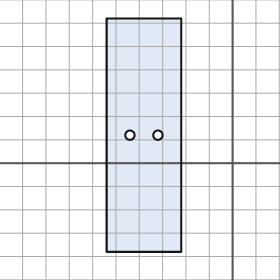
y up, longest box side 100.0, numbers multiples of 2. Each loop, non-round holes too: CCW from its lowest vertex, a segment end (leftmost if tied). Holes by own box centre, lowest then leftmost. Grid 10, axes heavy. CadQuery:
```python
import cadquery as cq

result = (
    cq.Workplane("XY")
    .moveTo(-54.0, -38.0)
    .lineTo(-22.0, -38.0)
    .lineTo(-22.0, 62.0)
    .lineTo(-54.0, 62.0)
    .close()
    .moveTo(-44.0, 12.0)
    .circle(2.0)
    .moveTo(-32.0, 12.0)
    .circle(2.0)
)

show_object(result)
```